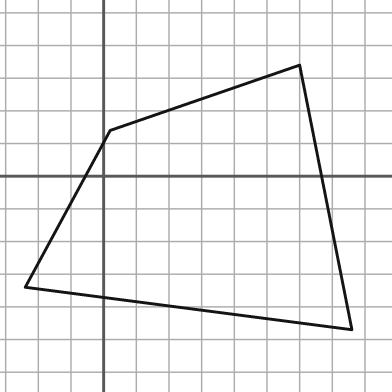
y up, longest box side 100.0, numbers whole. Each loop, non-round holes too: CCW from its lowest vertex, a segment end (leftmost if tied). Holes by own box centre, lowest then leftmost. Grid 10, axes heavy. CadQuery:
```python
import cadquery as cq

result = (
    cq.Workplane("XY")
    .moveTo(76.0, -47.0)
    .lineTo(60.0, 34.0)
    .lineTo(2.0, 14.0)
    .lineTo(-24.0, -34.0)
    .close()
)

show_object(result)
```